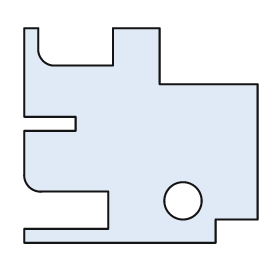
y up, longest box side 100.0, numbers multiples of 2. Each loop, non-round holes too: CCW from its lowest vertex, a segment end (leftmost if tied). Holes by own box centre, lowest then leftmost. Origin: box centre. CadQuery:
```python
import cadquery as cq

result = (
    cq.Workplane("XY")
    .moveTo(-50.0, -46.0)
    .lineTo(32.0, -46.0)
    .lineTo(32.0, -36.0)
    .lineTo(50.0, -36.0)
    .lineTo(50.0, 22.0)
    .lineTo(8.0, 22.0)
    .lineTo(8.0, 46.0)
    .lineTo(-12.0, 46.0)
    .lineTo(-12.0, 30.0)
    .lineTo(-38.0, 30.0)
    .threePointArc((-42.0, 32.0), (-44.0, 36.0))
    .lineTo(-44.0, 46.0)
    .lineTo(-50.0, 46.0)
    .lineTo(-50.0, 8.0)
    .lineTo(-28.0, 8.0)
    .lineTo(-28.0, 2.0)
    .lineTo(-50.0, 2.0)
    .lineTo(-50.0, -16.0)
    .threePointArc((-48.0, -22.0), (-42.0, -24.0))
    .lineTo(-14.0, -24.0)
    .lineTo(-14.0, -40.0)
    .lineTo(-50.0, -40.0)
    .close()
    .moveTo(18.0, -28.0)
    .circle(8.0)
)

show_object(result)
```